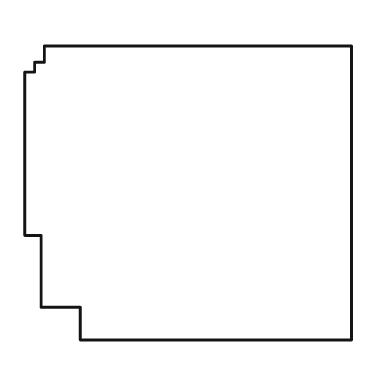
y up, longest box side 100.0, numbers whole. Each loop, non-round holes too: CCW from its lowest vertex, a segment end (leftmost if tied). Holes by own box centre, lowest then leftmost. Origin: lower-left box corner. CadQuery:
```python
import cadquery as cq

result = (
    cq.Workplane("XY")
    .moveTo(17.0, 0.0)
    .lineTo(100.0, 0.0)
    .lineTo(100.0, 90.0)
    .lineTo(6.0, 90.0)
    .lineTo(6.0, 85.0)
    .lineTo(3.0, 85.0)
    .lineTo(3.0, 82.0)
    .lineTo(0.0, 82.0)
    .lineTo(0.0, 32.0)
    .lineTo(5.0, 32.0)
    .lineTo(5.0, 10.0)
    .lineTo(17.0, 10.0)
    .close()
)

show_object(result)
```